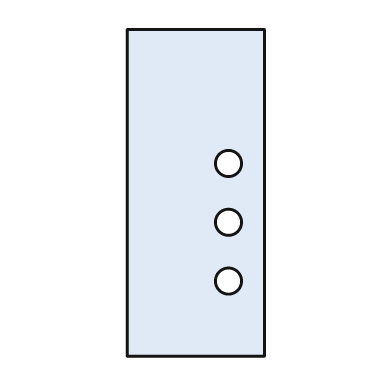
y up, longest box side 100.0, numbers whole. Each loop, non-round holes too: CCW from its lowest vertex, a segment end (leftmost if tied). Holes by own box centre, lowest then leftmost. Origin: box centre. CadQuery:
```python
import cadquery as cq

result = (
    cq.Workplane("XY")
    .moveTo(-21.0, -50.0)
    .lineTo(21.0, -50.0)
    .lineTo(21.0, 50.0)
    .lineTo(-21.0, 50.0)
    .close()
    .moveTo(10.0, -27.0)
    .circle(4.0)
    .moveTo(10.0, -9.0)
    .circle(4.0)
    .moveTo(10.0, 9.0)
    .circle(4.0)
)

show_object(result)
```